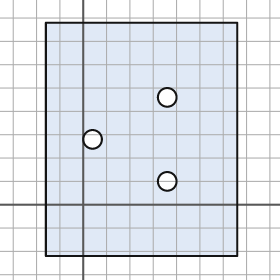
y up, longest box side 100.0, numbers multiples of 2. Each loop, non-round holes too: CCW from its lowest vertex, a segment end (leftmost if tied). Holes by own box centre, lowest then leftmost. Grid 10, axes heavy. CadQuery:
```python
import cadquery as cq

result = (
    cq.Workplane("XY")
    .moveTo(-16.0, -22.0)
    .lineTo(66.0, -22.0)
    .lineTo(66.0, 78.0)
    .lineTo(-16.0, 78.0)
    .close()
    .moveTo(36.0, 10.0)
    .circle(4.0)
    .moveTo(4.0, 28.0)
    .circle(4.0)
    .moveTo(36.0, 46.0)
    .circle(4.0)
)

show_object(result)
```